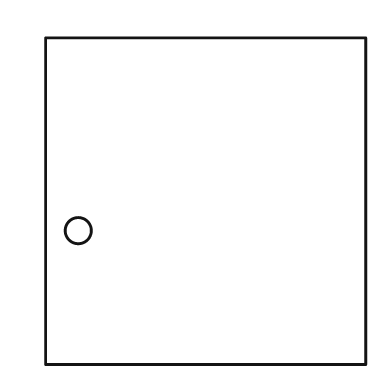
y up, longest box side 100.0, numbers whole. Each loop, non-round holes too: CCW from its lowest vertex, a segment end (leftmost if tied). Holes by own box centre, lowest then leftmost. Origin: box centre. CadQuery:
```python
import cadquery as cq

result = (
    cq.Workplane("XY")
    .moveTo(-49.0, -50.0)
    .lineTo(49.0, -50.0)
    .lineTo(49.0, 50.0)
    .lineTo(-49.0, 50.0)
    .close()
    .moveTo(-39.0, -9.0)
    .circle(4.0)
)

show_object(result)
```